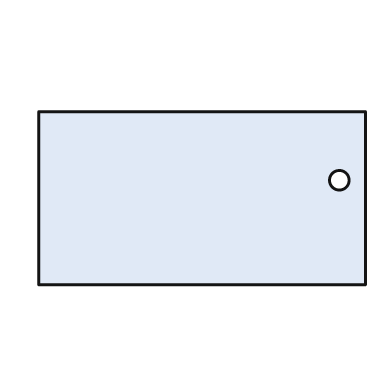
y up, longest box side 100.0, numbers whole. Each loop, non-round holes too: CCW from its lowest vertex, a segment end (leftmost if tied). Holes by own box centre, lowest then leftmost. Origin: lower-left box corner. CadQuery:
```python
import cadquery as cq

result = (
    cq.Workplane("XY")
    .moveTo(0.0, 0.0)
    .lineTo(100.0, 0.0)
    .lineTo(100.0, 53.0)
    .lineTo(0.0, 53.0)
    .close()
    .moveTo(92.0, 32.0)
    .circle(3.0)
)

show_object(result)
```